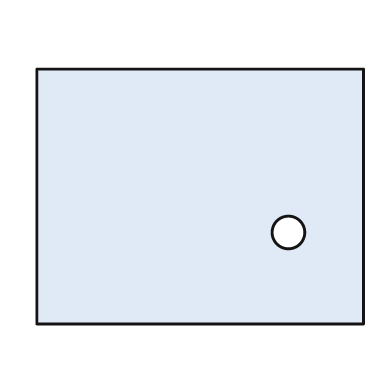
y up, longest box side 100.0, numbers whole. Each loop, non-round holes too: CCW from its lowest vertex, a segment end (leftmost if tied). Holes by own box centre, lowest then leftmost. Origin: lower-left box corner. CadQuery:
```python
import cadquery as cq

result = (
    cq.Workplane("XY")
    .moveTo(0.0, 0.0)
    .lineTo(100.0, 0.0)
    .lineTo(100.0, 78.0)
    .lineTo(0.0, 78.0)
    .close()
    .moveTo(77.0, 28.0)
    .circle(5.0)
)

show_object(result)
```